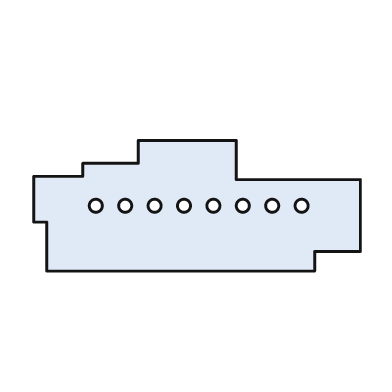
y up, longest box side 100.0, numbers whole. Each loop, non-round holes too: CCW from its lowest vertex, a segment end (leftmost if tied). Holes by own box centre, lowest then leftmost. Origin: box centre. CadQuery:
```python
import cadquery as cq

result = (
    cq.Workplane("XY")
    .moveTo(-46.0, -20.0)
    .lineTo(36.0, -20.0)
    .lineTo(36.0, -14.0)
    .lineTo(50.0, -14.0)
    .lineTo(50.0, 8.0)
    .lineTo(12.0, 8.0)
    .lineTo(12.0, 20.0)
    .lineTo(-18.0, 20.0)
    .lineTo(-18.0, 13.0)
    .lineTo(-35.0, 13.0)
    .lineTo(-35.0, 9.0)
    .lineTo(-50.0, 9.0)
    .lineTo(-50.0, -5.0)
    .lineTo(-46.0, -5.0)
    .close()
    .moveTo(-31.0, 0.0)
    .circle(2.0)
    .moveTo(-22.0, 0.0)
    .circle(2.0)
    .moveTo(-13.0, 0.0)
    .circle(2.0)
    .moveTo(-4.0, 0.0)
    .circle(2.0)
    .moveTo(5.0, 0.0)
    .circle(2.0)
    .moveTo(14.0, 0.0)
    .circle(2.0)
    .moveTo(23.0, 0.0)
    .circle(2.0)
    .moveTo(32.0, 0.0)
    .circle(2.0)
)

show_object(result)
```